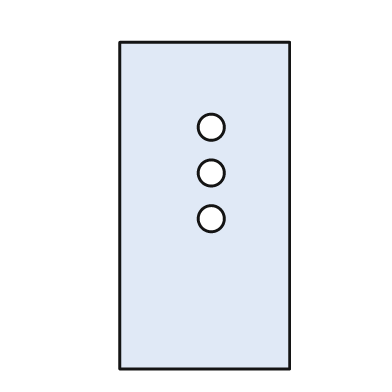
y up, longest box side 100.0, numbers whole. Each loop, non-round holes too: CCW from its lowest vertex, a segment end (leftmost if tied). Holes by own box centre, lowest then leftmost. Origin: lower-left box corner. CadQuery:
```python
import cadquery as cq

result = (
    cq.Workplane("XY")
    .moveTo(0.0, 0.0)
    .lineTo(52.0, 0.0)
    .lineTo(52.0, 100.0)
    .lineTo(0.0, 100.0)
    .close()
    .moveTo(28.0, 46.0)
    .circle(4.0)
    .moveTo(28.0, 60.0)
    .circle(4.0)
    .moveTo(28.0, 74.0)
    .circle(4.0)
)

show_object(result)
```